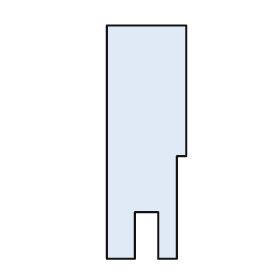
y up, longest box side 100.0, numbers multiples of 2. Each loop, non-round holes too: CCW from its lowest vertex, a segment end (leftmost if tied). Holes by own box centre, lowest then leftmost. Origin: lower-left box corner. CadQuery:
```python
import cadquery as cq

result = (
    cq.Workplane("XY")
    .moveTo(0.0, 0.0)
    .lineTo(12.0, 0.0)
    .lineTo(12.0, 20.0)
    .lineTo(22.0, 20.0)
    .lineTo(22.0, 0.0)
    .lineTo(30.0, 0.0)
    .lineTo(30.0, 44.0)
    .lineTo(34.0, 44.0)
    .lineTo(34.0, 100.0)
    .lineTo(0.0, 100.0)
    .close()
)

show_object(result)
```